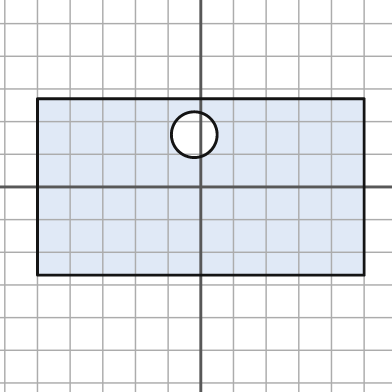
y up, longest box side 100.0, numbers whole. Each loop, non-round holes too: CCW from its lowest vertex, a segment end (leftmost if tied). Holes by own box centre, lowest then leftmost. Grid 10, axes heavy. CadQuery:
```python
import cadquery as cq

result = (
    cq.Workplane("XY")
    .moveTo(-50.0, -27.0)
    .lineTo(50.0, -27.0)
    .lineTo(50.0, 27.0)
    .lineTo(-50.0, 27.0)
    .close()
    .moveTo(-2.0, 16.0)
    .circle(7.0)
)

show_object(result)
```